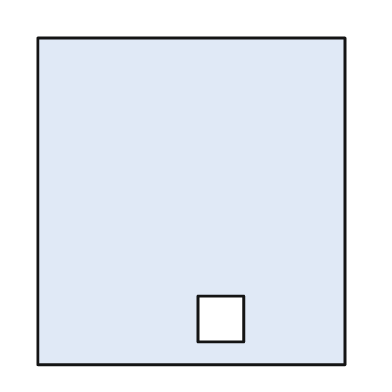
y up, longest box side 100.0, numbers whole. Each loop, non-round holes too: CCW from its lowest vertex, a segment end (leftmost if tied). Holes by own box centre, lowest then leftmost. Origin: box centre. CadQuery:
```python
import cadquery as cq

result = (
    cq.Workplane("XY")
    .moveTo(-47.0, -50.0)
    .lineTo(47.0, -50.0)
    .lineTo(47.0, 50.0)
    .lineTo(-47.0, 50.0)
    .close()
    .moveTo(2.0, -43.0)
    .lineTo(16.0, -43.0)
    .lineTo(16.0, -29.0)
    .lineTo(2.0, -29.0)
    .close()
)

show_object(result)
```